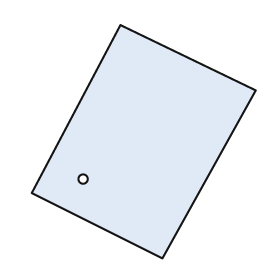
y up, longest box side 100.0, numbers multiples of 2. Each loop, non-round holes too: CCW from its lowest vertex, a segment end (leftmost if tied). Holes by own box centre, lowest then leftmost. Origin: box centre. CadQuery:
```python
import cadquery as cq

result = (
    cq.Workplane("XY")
    .moveTo(8.0, -50.0)
    .lineTo(48.0, 22.0)
    .lineTo(-10.0, 50.0)
    .lineTo(-48.0, -22.0)
    .close()
    .moveTo(-26.0, -16.0)
    .circle(2.0)
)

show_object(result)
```